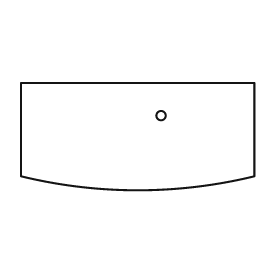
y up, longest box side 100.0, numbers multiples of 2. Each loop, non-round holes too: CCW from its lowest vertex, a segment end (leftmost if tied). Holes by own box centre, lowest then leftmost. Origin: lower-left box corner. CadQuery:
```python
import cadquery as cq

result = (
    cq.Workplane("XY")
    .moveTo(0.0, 6.0)
    .threePointArc((50.0, 0.0), (100.0, 6.0))
    .lineTo(100.0, 46.0)
    .lineTo(0.0, 46.0)
    .close()
    .moveTo(60.0, 32.0)
    .circle(2.0)
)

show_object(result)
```